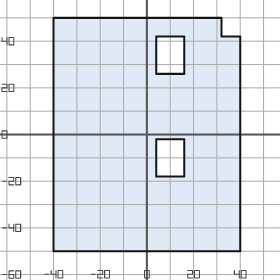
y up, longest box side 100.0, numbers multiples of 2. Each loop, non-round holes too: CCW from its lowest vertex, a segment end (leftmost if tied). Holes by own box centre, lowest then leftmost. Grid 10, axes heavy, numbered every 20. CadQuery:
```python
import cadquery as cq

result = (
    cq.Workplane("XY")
    .moveTo(-40.0, -50.0)
    .lineTo(40.0, -50.0)
    .lineTo(40.0, 42.0)
    .lineTo(32.0, 42.0)
    .lineTo(32.0, 50.0)
    .lineTo(-40.0, 50.0)
    .close()
    .moveTo(4.0, -18.0)
    .lineTo(16.0, -18.0)
    .lineTo(16.0, -2.0)
    .lineTo(4.0, -2.0)
    .close()
    .moveTo(4.0, 26.0)
    .lineTo(16.0, 26.0)
    .lineTo(16.0, 42.0)
    .lineTo(4.0, 42.0)
    .close()
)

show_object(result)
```